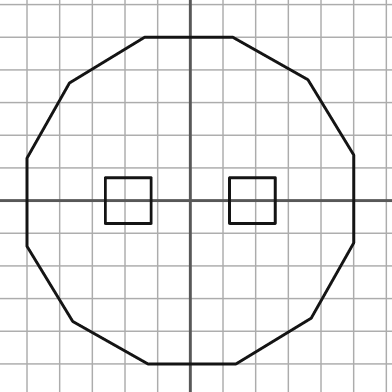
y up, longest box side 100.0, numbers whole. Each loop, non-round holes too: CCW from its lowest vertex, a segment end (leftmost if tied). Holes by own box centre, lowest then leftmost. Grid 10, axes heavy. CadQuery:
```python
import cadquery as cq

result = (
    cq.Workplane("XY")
    .moveTo(-13.0, -50.0)
    .lineTo(14.0, -50.0)
    .lineTo(37.0, -36.0)
    .lineTo(50.0, -13.0)
    .lineTo(50.0, 14.0)
    .lineTo(36.0, 37.0)
    .lineTo(13.0, 50.0)
    .lineTo(-14.0, 50.0)
    .lineTo(-37.0, 36.0)
    .lineTo(-50.0, 13.0)
    .lineTo(-50.0, -14.0)
    .lineTo(-36.0, -37.0)
    .close()
    .moveTo(-26.0, -7.0)
    .lineTo(-12.0, -7.0)
    .lineTo(-12.0, 7.0)
    .lineTo(-26.0, 7.0)
    .close()
    .moveTo(12.0, -7.0)
    .lineTo(26.0, -7.0)
    .lineTo(26.0, 7.0)
    .lineTo(12.0, 7.0)
    .close()
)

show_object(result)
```